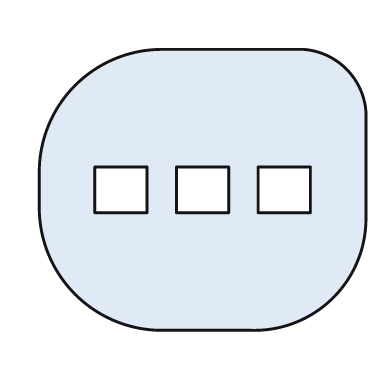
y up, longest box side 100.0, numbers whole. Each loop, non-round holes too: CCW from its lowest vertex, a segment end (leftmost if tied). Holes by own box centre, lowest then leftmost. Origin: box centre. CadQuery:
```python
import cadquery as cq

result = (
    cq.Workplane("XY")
    .moveTo(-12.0, -43.0)
    .lineTo(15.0, -43.0)
    .threePointArc((40.0, -33.0), (50.0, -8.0))
    .lineTo(50.0, 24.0)
    .threePointArc((44.0, 37.0), (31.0, 43.0))
    .lineTo(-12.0, 43.0)
    .threePointArc((-39.0, 32.0), (-50.0, 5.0))
    .lineTo(-50.0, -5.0)
    .threePointArc((-39.0, -32.0), (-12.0, -43.0))
    .close()
    .moveTo(-33.0, -7.0)
    .lineTo(-17.0, -7.0)
    .lineTo(-17.0, 7.0)
    .lineTo(-33.0, 7.0)
    .close()
    .moveTo(-8.0, -7.0)
    .lineTo(8.0, -7.0)
    .lineTo(8.0, 7.0)
    .lineTo(-8.0, 7.0)
    .close()
    .moveTo(17.0, -7.0)
    .lineTo(33.0, -7.0)
    .lineTo(33.0, 7.0)
    .lineTo(17.0, 7.0)
    .close()
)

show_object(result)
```